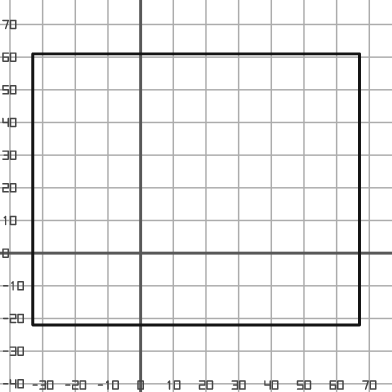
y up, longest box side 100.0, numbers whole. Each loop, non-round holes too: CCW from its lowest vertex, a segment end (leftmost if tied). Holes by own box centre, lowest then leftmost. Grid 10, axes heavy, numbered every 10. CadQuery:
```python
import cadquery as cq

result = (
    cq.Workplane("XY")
    .moveTo(-33.0, -22.0)
    .lineTo(67.0, -22.0)
    .lineTo(67.0, 61.0)
    .lineTo(-33.0, 61.0)
    .close()
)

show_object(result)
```